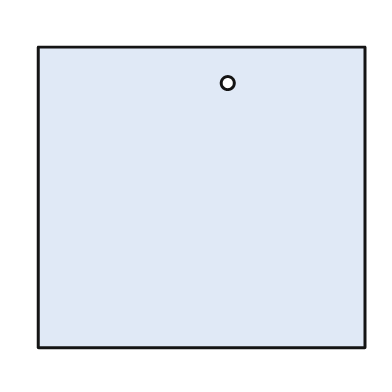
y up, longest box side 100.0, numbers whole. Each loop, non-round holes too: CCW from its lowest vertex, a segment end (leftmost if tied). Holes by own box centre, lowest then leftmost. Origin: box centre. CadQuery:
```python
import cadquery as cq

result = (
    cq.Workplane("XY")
    .moveTo(-50.0, -46.0)
    .lineTo(50.0, -46.0)
    .lineTo(50.0, 46.0)
    .lineTo(-50.0, 46.0)
    .close()
    .moveTo(8.0, 35.0)
    .circle(2.0)
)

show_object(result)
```